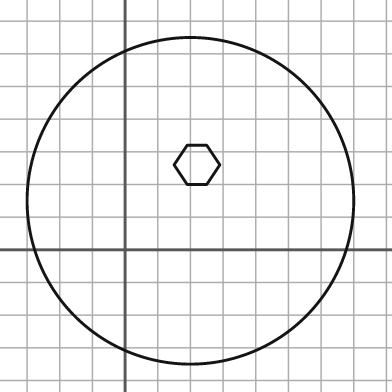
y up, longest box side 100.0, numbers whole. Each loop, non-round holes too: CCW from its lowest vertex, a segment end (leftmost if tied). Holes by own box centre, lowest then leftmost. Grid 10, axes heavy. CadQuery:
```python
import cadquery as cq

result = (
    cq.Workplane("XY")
    .moveTo(20.0, 15.0)
    .circle(50.0)
    .moveTo(19.0, 20.0)
    .lineTo(25.0, 20.0)
    .lineTo(29.0, 26.0)
    .lineTo(25.0, 32.0)
    .lineTo(19.0, 32.0)
    .lineTo(15.0, 26.0)
    .close()
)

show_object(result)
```